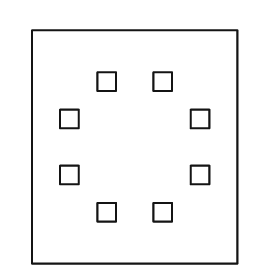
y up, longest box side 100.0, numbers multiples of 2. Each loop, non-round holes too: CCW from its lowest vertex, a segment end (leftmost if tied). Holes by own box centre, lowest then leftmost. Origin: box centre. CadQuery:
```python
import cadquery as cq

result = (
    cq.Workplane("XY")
    .moveTo(-44.0, -50.0)
    .lineTo(44.0, -50.0)
    .lineTo(44.0, 50.0)
    .lineTo(-44.0, 50.0)
    .close()
    .moveTo(-16.0, -32.0)
    .lineTo(-8.0, -32.0)
    .lineTo(-8.0, -24.0)
    .lineTo(-16.0, -24.0)
    .close()
    .moveTo(8.0, -32.0)
    .lineTo(16.0, -32.0)
    .lineTo(16.0, -24.0)
    .lineTo(8.0, -24.0)
    .close()
    .moveTo(-32.0, -16.0)
    .lineTo(-24.0, -16.0)
    .lineTo(-24.0, -8.0)
    .lineTo(-32.0, -8.0)
    .close()
    .moveTo(24.0, -16.0)
    .lineTo(32.0, -16.0)
    .lineTo(32.0, -8.0)
    .lineTo(24.0, -8.0)
    .close()
    .moveTo(-32.0, 8.0)
    .lineTo(-24.0, 8.0)
    .lineTo(-24.0, 16.0)
    .lineTo(-32.0, 16.0)
    .close()
    .moveTo(24.0, 8.0)
    .lineTo(32.0, 8.0)
    .lineTo(32.0, 16.0)
    .lineTo(24.0, 16.0)
    .close()
    .moveTo(-16.0, 24.0)
    .lineTo(-8.0, 24.0)
    .lineTo(-8.0, 32.0)
    .lineTo(-16.0, 32.0)
    .close()
    .moveTo(8.0, 24.0)
    .lineTo(16.0, 24.0)
    .lineTo(16.0, 32.0)
    .lineTo(8.0, 32.0)
    .close()
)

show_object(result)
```